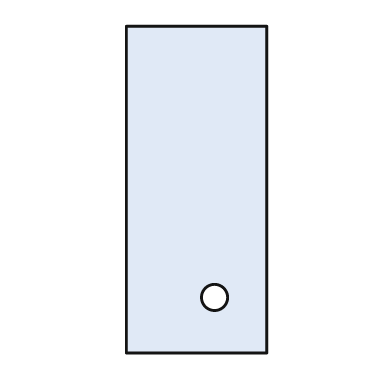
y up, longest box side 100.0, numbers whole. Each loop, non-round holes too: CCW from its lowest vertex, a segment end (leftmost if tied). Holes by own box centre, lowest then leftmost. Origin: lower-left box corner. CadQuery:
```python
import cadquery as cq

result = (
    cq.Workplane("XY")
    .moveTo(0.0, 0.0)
    .lineTo(43.0, 0.0)
    .lineTo(43.0, 100.0)
    .lineTo(0.0, 100.0)
    .close()
    .moveTo(27.0, 17.0)
    .circle(4.0)
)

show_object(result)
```